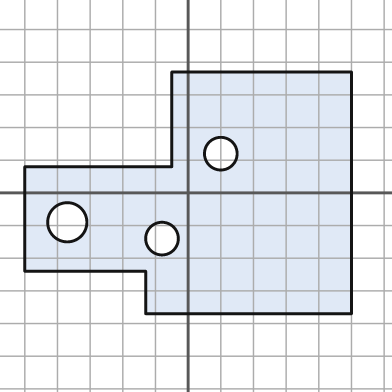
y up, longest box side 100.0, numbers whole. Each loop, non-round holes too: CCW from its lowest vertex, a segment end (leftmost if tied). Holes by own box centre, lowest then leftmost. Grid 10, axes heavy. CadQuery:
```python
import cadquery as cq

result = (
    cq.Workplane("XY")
    .moveTo(-13.0, -37.0)
    .lineTo(50.0, -37.0)
    .lineTo(50.0, 37.0)
    .lineTo(-5.0, 37.0)
    .lineTo(-5.0, 8.0)
    .lineTo(-50.0, 8.0)
    .lineTo(-50.0, -24.0)
    .lineTo(-13.0, -24.0)
    .close()
    .moveTo(-8.0, -14.0)
    .circle(5.0)
    .moveTo(-37.0, -9.0)
    .circle(6.0)
    .moveTo(10.0, 12.0)
    .circle(5.0)
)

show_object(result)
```